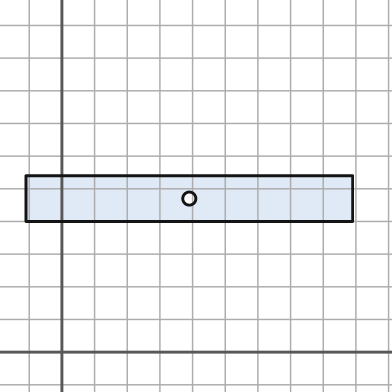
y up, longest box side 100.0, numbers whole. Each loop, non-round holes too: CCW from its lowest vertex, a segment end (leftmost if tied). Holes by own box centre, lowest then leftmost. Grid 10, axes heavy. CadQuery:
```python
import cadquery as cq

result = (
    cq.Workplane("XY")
    .moveTo(-11.0, 40.0)
    .lineTo(89.0, 40.0)
    .lineTo(89.0, 54.0)
    .lineTo(-11.0, 54.0)
    .close()
    .moveTo(39.0, 47.0)
    .circle(2.0)
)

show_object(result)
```